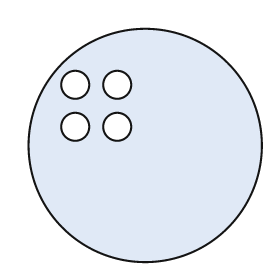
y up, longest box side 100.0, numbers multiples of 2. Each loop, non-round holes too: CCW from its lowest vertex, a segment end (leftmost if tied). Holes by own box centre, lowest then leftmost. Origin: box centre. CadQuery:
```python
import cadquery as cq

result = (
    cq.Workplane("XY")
    .moveTo(0.0, 0.0)
    .circle(50.0)
    .moveTo(-30.0, 8.0)
    .circle(6.0)
    .moveTo(-12.0, 8.0)
    .circle(6.0)
    .moveTo(-30.0, 26.0)
    .circle(6.0)
    .moveTo(-12.0, 26.0)
    .circle(6.0)
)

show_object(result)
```